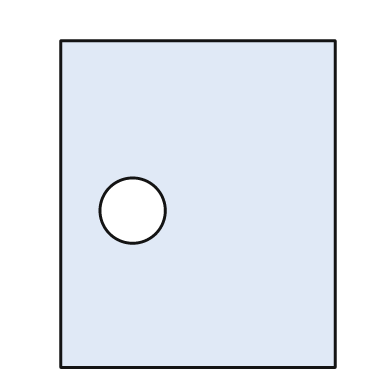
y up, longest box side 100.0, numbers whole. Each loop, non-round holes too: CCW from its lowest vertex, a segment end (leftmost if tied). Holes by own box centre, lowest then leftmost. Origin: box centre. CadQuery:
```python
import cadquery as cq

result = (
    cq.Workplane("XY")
    .moveTo(-42.0, -50.0)
    .lineTo(42.0, -50.0)
    .lineTo(42.0, 50.0)
    .lineTo(-42.0, 50.0)
    .close()
    .moveTo(-20.0, -2.0)
    .circle(10.0)
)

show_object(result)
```